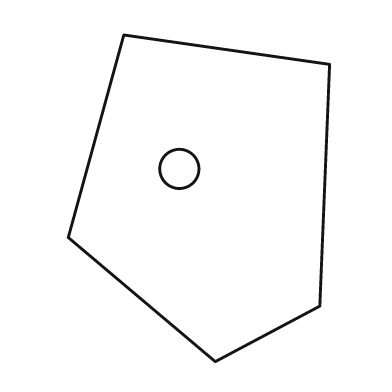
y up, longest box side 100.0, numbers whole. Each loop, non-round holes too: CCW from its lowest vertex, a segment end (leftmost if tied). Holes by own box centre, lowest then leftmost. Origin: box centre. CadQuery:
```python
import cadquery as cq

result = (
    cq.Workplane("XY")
    .moveTo(5.0, -50.0)
    .lineTo(37.0, -33.0)
    .lineTo(40.0, 41.0)
    .lineTo(-23.0, 50.0)
    .lineTo(-40.0, -12.0)
    .close()
    .moveTo(-6.0, 9.0)
    .circle(6.0)
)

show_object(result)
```